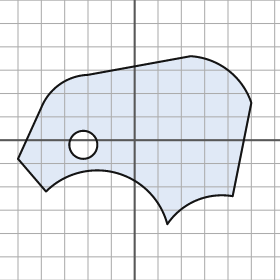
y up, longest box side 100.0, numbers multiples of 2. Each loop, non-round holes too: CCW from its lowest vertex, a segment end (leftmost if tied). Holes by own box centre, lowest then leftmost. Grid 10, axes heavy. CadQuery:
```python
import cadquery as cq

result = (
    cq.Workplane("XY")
    .moveTo(14.0, -36.0)
    .threePointArc((26.0, -26.0), (42.0, -24.0))
    .lineTo(50.0, 16.0)
    .threePointArc((40.0, 30.0), (24.0, 36.0))
    .lineTo(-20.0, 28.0)
    .threePointArc((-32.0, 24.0), (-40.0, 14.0))
    .lineTo(-50.0, -8.0)
    .lineTo(-38.0, -22.0)
    .threePointArc((-8.0, -14.0), (14.0, -36.0))
    .close()
    .moveTo(-22.0, -2.0)
    .circle(6.0)
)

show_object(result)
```